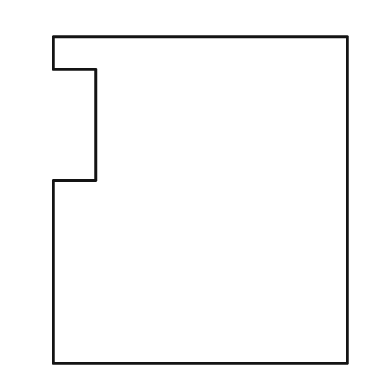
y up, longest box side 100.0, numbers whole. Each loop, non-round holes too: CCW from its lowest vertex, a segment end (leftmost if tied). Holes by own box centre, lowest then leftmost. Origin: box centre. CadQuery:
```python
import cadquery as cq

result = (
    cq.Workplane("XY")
    .moveTo(-45.0, -50.0)
    .lineTo(45.0, -50.0)
    .lineTo(45.0, 50.0)
    .lineTo(-45.0, 50.0)
    .lineTo(-45.0, 40.0)
    .lineTo(-32.0, 40.0)
    .lineTo(-32.0, 6.0)
    .lineTo(-45.0, 6.0)
    .close()
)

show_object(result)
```